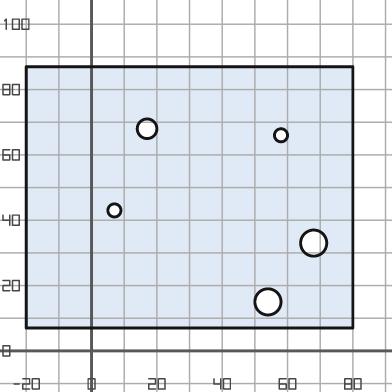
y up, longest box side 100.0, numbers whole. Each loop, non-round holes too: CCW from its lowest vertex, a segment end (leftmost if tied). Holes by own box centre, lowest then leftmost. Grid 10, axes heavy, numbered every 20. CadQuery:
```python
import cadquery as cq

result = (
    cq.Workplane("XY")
    .moveTo(-20.0, 7.0)
    .lineTo(80.0, 7.0)
    .lineTo(80.0, 87.0)
    .lineTo(-20.0, 87.0)
    .close()
    .moveTo(54.0, 15.0)
    .circle(4.0)
    .moveTo(68.0, 33.0)
    .circle(4.0)
    .moveTo(7.0, 43.0)
    .circle(2.0)
    .moveTo(58.0, 66.0)
    .circle(2.0)
    .moveTo(17.0, 68.0)
    .circle(3.0)
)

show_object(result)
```